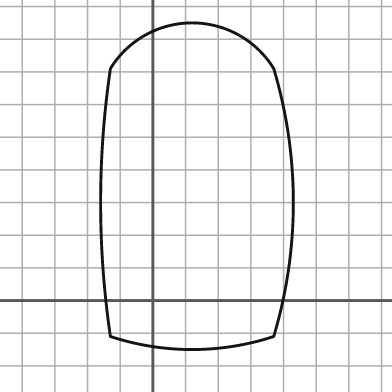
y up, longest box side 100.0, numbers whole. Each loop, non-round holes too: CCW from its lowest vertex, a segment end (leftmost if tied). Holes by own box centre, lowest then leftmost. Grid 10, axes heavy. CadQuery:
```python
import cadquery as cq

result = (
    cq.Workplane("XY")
    .moveTo(-13.0, -11.0)
    .threePointArc((12.0, -15.0), (37.0, -11.0))
    .threePointArc((43.0, 30.0), (37.0, 71.0))
    .threePointArc((12.0, 85.0), (-13.0, 71.0))
    .threePointArc((-16.0, 30.0), (-13.0, -11.0))
    .close()
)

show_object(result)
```